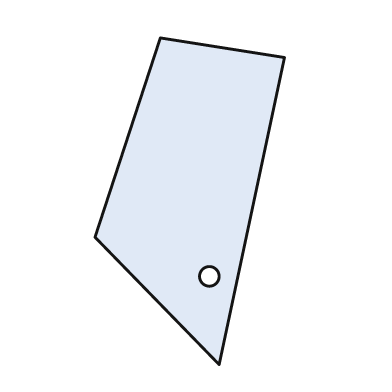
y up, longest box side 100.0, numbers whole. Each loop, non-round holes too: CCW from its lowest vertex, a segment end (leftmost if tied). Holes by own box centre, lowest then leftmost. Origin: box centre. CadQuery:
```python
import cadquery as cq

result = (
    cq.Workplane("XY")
    .moveTo(9.0, -50.0)
    .lineTo(29.0, 44.0)
    .lineTo(-9.0, 50.0)
    .lineTo(-29.0, -11.0)
    .close()
    .moveTo(6.0, -23.0)
    .circle(3.0)
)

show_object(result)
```